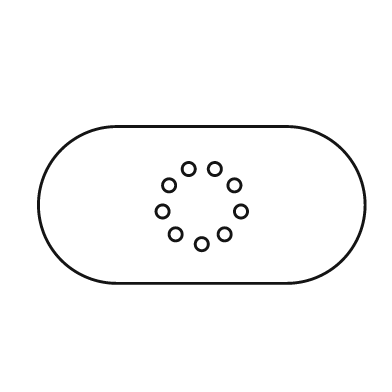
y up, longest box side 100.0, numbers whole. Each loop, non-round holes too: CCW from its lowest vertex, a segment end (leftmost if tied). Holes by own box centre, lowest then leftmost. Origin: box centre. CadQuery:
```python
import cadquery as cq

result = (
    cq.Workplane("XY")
    .moveTo(-26.0, -24.0)
    .lineTo(26.0, -24.0)
    .threePointArc((50.0, 0.0), (26.0, 24.0))
    .lineTo(-26.0, 24.0)
    .threePointArc((-50.0, 0.0), (-26.0, -24.0))
    .close()
    .moveTo(0.0, -12.0)
    .circle(2.0)
    .moveTo(-8.0, -9.0)
    .circle(2.0)
    .moveTo(7.0, -9.0)
    .circle(2.0)
    .moveTo(-12.0, -2.0)
    .circle(2.0)
    .moveTo(12.0, -2.0)
    .circle(2.0)
    .moveTo(-10.0, 6.0)
    .circle(2.0)
    .moveTo(10.0, 6.0)
    .circle(2.0)
    .moveTo(-4.0, 11.0)
    .circle(2.0)
    .moveTo(4.0, 11.0)
    .circle(2.0)
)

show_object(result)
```